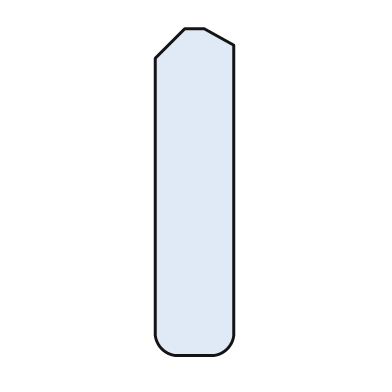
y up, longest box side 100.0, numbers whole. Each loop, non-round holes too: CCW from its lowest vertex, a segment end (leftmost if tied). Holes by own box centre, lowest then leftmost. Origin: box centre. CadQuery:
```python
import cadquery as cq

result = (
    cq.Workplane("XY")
    .moveTo(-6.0, -50.0)
    .lineTo(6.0, -50.0)
    .threePointArc((10.0, -48.0), (12.0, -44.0))
    .lineTo(12.0, 45.0)
    .lineTo(3.0, 50.0)
    .lineTo(-3.0, 50.0)
    .lineTo(-12.0, 41.0)
    .lineTo(-12.0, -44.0)
    .threePointArc((-10.0, -48.0), (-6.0, -50.0))
    .close()
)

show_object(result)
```